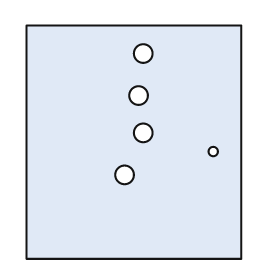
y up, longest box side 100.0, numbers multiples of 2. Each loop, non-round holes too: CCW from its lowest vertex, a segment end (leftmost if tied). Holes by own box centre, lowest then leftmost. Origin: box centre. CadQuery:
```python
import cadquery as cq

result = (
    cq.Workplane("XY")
    .moveTo(-46.0, -50.0)
    .lineTo(46.0, -50.0)
    .lineTo(46.0, 50.0)
    .lineTo(-46.0, 50.0)
    .close()
    .moveTo(-4.0, -14.0)
    .circle(4.0)
    .moveTo(34.0, -4.0)
    .circle(2.0)
    .moveTo(4.0, 4.0)
    .circle(4.0)
    .moveTo(2.0, 20.0)
    .circle(4.0)
    .moveTo(4.0, 38.0)
    .circle(4.0)
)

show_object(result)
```